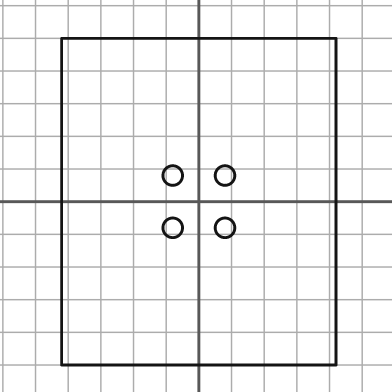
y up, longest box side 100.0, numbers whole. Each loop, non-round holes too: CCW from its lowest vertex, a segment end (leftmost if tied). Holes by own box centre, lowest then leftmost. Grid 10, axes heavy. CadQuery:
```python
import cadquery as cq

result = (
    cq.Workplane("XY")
    .moveTo(-42.0, -50.0)
    .lineTo(42.0, -50.0)
    .lineTo(42.0, 50.0)
    .lineTo(-42.0, 50.0)
    .close()
    .moveTo(-8.0, -8.0)
    .circle(3.0)
    .moveTo(8.0, -8.0)
    .circle(3.0)
    .moveTo(-8.0, 8.0)
    .circle(3.0)
    .moveTo(8.0, 8.0)
    .circle(3.0)
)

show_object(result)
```